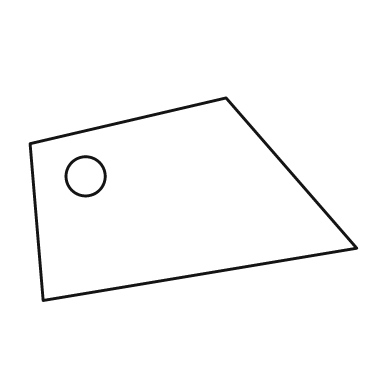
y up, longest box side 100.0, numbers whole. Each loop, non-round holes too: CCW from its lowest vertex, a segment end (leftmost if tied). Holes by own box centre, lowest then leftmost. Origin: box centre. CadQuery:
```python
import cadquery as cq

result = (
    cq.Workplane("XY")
    .moveTo(-46.0, -31.0)
    .lineTo(50.0, -15.0)
    .lineTo(10.0, 31.0)
    .lineTo(-50.0, 17.0)
    .close()
    .moveTo(-33.0, 7.0)
    .circle(6.0)
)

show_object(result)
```